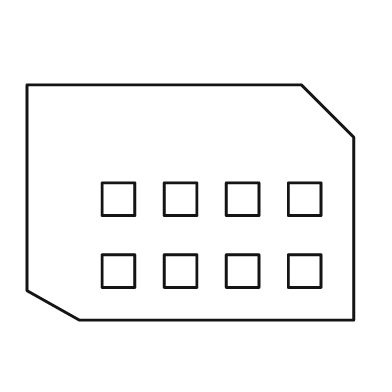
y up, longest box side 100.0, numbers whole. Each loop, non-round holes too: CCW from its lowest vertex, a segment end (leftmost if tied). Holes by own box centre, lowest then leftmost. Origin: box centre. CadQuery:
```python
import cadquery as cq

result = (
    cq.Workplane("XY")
    .moveTo(-34.0, -36.0)
    .lineTo(50.0, -36.0)
    .lineTo(50.0, 20.0)
    .lineTo(34.0, 36.0)
    .lineTo(-50.0, 36.0)
    .lineTo(-50.0, -27.0)
    .close()
    .moveTo(-27.0, -26.0)
    .lineTo(-17.0, -26.0)
    .lineTo(-17.0, -16.0)
    .lineTo(-27.0, -16.0)
    .close()
    .moveTo(-8.0, -26.0)
    .lineTo(2.0, -26.0)
    .lineTo(2.0, -16.0)
    .lineTo(-8.0, -16.0)
    .close()
    .moveTo(11.0, -26.0)
    .lineTo(21.0, -26.0)
    .lineTo(21.0, -16.0)
    .lineTo(11.0, -16.0)
    .close()
    .moveTo(30.0, -26.0)
    .lineTo(40.0, -26.0)
    .lineTo(40.0, -16.0)
    .lineTo(30.0, -16.0)
    .close()
    .moveTo(-27.0, -4.0)
    .lineTo(-17.0, -4.0)
    .lineTo(-17.0, 6.0)
    .lineTo(-27.0, 6.0)
    .close()
    .moveTo(-8.0, -4.0)
    .lineTo(2.0, -4.0)
    .lineTo(2.0, 6.0)
    .lineTo(-8.0, 6.0)
    .close()
    .moveTo(11.0, -4.0)
    .lineTo(21.0, -4.0)
    .lineTo(21.0, 6.0)
    .lineTo(11.0, 6.0)
    .close()
    .moveTo(30.0, -4.0)
    .lineTo(40.0, -4.0)
    .lineTo(40.0, 6.0)
    .lineTo(30.0, 6.0)
    .close()
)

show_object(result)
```